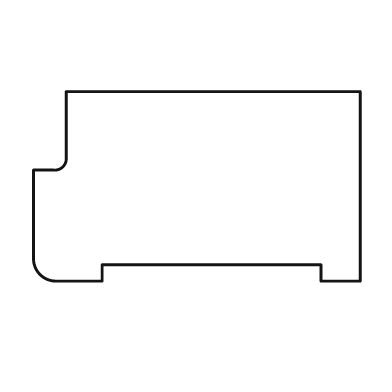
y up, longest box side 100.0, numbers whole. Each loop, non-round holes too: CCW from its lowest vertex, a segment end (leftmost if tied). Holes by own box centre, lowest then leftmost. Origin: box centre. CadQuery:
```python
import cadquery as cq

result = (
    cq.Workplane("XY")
    .moveTo(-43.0, -29.0)
    .lineTo(-29.0, -29.0)
    .lineTo(-29.0, -24.0)
    .lineTo(38.0, -24.0)
    .lineTo(38.0, -29.0)
    .lineTo(50.0, -29.0)
    .lineTo(50.0, 29.0)
    .lineTo(-40.0, 29.0)
    .lineTo(-40.0, 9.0)
    .threePointArc((-41.0, 6.0), (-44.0, 5.0))
    .lineTo(-50.0, 5.0)
    .lineTo(-50.0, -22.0)
    .threePointArc((-48.0, -27.0), (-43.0, -29.0))
    .close()
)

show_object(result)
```